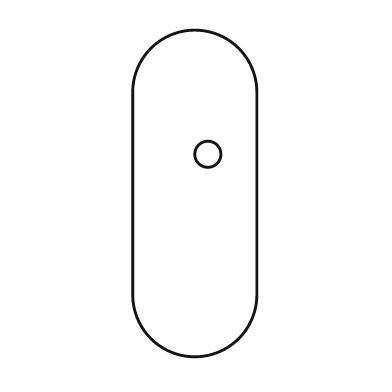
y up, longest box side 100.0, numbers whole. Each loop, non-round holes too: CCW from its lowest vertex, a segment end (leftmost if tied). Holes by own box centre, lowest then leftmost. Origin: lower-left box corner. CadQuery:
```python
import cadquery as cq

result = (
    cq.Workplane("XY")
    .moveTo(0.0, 19.0)
    .threePointArc((19.0, 0.0), (38.0, 19.0))
    .lineTo(38.0, 81.0)
    .threePointArc((19.0, 100.0), (0.0, 81.0))
    .close()
    .moveTo(23.0, 62.0)
    .circle(4.0)
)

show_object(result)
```